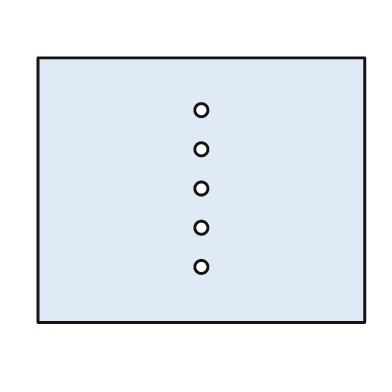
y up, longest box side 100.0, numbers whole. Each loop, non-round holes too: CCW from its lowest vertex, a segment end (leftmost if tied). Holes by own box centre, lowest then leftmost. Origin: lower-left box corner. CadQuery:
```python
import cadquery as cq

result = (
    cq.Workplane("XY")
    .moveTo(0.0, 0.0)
    .lineTo(100.0, 0.0)
    .lineTo(100.0, 81.0)
    .lineTo(0.0, 81.0)
    .close()
    .moveTo(50.0, 17.0)
    .circle(2.0)
    .moveTo(50.0, 29.0)
    .circle(2.0)
    .moveTo(50.0, 41.0)
    .circle(2.0)
    .moveTo(50.0, 53.0)
    .circle(2.0)
    .moveTo(50.0, 65.0)
    .circle(2.0)
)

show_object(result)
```